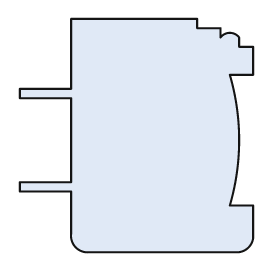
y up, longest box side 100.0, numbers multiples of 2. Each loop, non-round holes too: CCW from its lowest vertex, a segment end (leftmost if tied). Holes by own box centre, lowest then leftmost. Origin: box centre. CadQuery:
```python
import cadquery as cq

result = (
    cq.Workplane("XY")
    .moveTo(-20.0, -50.0)
    .lineTo(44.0, -50.0)
    .threePointArc((48.0, -48.0), (50.0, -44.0))
    .lineTo(50.0, -30.0)
    .lineTo(40.0, -30.0)
    .threePointArc((44.0, -2.0), (40.0, 26.0))
    .lineTo(50.0, 26.0)
    .lineTo(50.0, 38.0)
    .lineTo(44.0, 38.0)
    .lineTo(44.0, 42.0)
    .threePointArc((40.0, 44.0), (36.0, 42.0))
    .lineTo(36.0, 46.0)
    .lineTo(26.0, 46.0)
    .lineTo(26.0, 50.0)
    .lineTo(-28.0, 50.0)
    .lineTo(-28.0, 20.0)
    .lineTo(-50.0, 20.0)
    .lineTo(-50.0, 16.0)
    .lineTo(-28.0, 16.0)
    .lineTo(-28.0, -20.0)
    .lineTo(-50.0, -20.0)
    .lineTo(-50.0, -24.0)
    .lineTo(-28.0, -24.0)
    .lineTo(-28.0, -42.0)
    .threePointArc((-26.0, -48.0), (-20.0, -50.0))
    .close()
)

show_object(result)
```